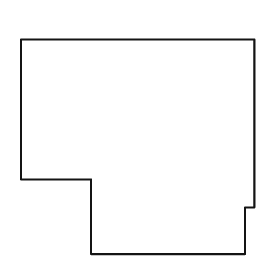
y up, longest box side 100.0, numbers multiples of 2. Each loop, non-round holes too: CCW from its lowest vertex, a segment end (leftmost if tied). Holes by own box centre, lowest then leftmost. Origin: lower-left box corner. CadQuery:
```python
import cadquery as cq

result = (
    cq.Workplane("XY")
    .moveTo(30.0, 0.0)
    .lineTo(96.0, 0.0)
    .lineTo(96.0, 20.0)
    .lineTo(100.0, 20.0)
    .lineTo(100.0, 92.0)
    .lineTo(0.0, 92.0)
    .lineTo(0.0, 32.0)
    .lineTo(30.0, 32.0)
    .close()
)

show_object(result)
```